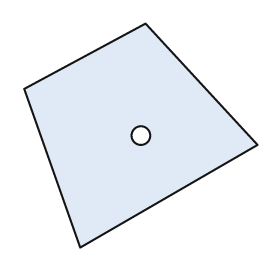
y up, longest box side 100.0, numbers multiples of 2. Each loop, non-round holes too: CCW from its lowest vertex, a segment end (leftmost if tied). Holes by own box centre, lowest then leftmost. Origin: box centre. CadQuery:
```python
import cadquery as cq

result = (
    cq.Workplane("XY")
    .moveTo(-26.0, -48.0)
    .lineTo(50.0, -4.0)
    .lineTo(2.0, 48.0)
    .lineTo(-50.0, 20.0)
    .close()
    .moveTo(0.0, 0.0)
    .circle(4.0)
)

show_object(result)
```